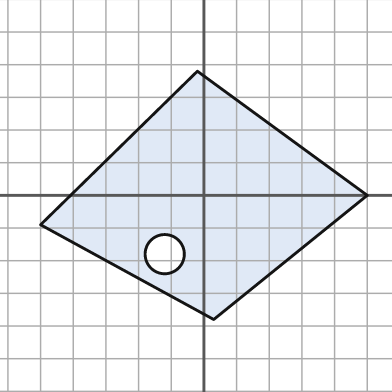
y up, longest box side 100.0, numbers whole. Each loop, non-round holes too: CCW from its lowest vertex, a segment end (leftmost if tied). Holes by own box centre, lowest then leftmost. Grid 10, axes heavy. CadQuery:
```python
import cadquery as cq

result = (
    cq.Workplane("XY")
    .moveTo(3.0, -38.0)
    .lineTo(50.0, 0.0)
    .lineTo(-2.0, 38.0)
    .lineTo(-50.0, -9.0)
    .close()
    .moveTo(-12.0, -18.0)
    .circle(6.0)
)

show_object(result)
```